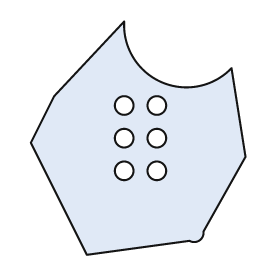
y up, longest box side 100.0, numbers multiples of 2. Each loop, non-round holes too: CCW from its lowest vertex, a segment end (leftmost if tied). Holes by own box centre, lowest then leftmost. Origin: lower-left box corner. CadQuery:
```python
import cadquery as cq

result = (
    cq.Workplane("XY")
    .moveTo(24.0, 0.0)
    .lineTo(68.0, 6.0)
    .threePointArc((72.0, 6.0), (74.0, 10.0))
    .lineTo(92.0, 42.0)
    .lineTo(86.0, 80.0)
    .threePointArc((56.0, 74.0), (40.0, 100.0))
    .lineTo(10.0, 68.0)
    .lineTo(0.0, 48.0)
    .close()
    .moveTo(40.0, 36.0)
    .circle(4.0)
    .moveTo(54.0, 36.0)
    .circle(4.0)
    .moveTo(40.0, 50.0)
    .circle(4.0)
    .moveTo(54.0, 50.0)
    .circle(4.0)
    .moveTo(40.0, 64.0)
    .circle(4.0)
    .moveTo(54.0, 64.0)
    .circle(4.0)
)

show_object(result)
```